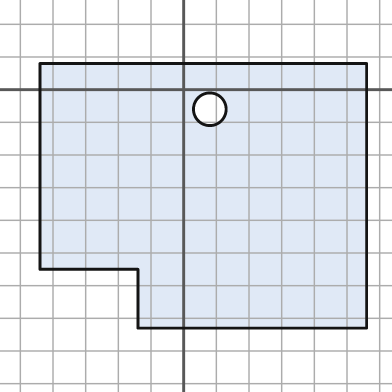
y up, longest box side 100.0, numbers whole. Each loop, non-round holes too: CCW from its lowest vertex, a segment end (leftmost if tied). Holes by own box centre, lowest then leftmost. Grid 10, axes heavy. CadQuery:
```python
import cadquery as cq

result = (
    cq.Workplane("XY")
    .moveTo(-14.0, -73.0)
    .lineTo(56.0, -73.0)
    .lineTo(56.0, 8.0)
    .lineTo(-44.0, 8.0)
    .lineTo(-44.0, -55.0)
    .lineTo(-14.0, -55.0)
    .close()
    .moveTo(8.0, -6.0)
    .circle(5.0)
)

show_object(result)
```